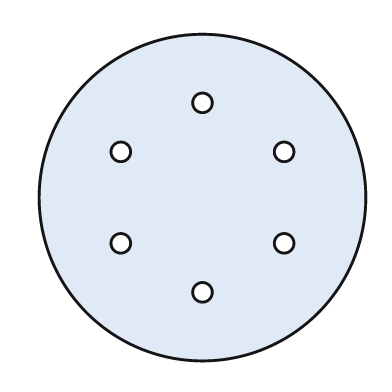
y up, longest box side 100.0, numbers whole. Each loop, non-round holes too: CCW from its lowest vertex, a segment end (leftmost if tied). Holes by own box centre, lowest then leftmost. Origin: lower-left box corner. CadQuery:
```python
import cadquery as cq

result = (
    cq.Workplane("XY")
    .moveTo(50.0, 50.0)
    .circle(50.0)
    .moveTo(50.0, 21.0)
    .circle(3.0)
    .moveTo(25.0, 36.0)
    .circle(3.0)
    .moveTo(75.0, 36.0)
    .circle(3.0)
    .moveTo(25.0, 64.0)
    .circle(3.0)
    .moveTo(75.0, 64.0)
    .circle(3.0)
    .moveTo(50.0, 79.0)
    .circle(3.0)
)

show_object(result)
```